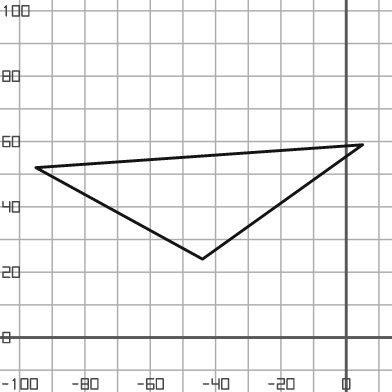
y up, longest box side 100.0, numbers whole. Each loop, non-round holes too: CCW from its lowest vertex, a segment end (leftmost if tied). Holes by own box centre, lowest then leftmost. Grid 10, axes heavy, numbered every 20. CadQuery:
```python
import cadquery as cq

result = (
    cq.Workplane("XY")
    .moveTo(-44.0, 24.0)
    .lineTo(5.0, 59.0)
    .lineTo(-95.0, 52.0)
    .close()
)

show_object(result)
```